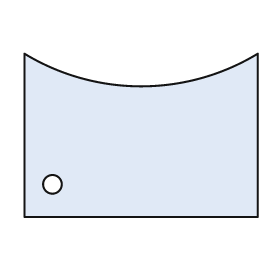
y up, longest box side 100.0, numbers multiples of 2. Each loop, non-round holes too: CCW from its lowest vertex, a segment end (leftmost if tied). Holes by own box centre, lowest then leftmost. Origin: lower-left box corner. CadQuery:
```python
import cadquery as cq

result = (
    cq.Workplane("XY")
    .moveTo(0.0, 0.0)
    .lineTo(100.0, 0.0)
    .lineTo(100.0, 70.0)
    .threePointArc((50.0, 56.0), (0.0, 70.0))
    .close()
    .moveTo(12.0, 14.0)
    .circle(4.0)
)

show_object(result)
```